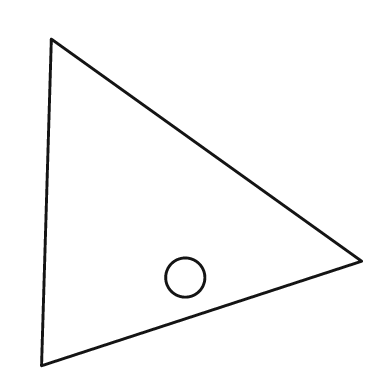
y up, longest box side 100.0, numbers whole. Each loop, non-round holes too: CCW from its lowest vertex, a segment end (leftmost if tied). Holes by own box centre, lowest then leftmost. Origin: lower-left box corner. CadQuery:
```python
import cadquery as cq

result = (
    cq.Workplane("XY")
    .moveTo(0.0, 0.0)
    .lineTo(98.0, 32.0)
    .lineTo(3.0, 100.0)
    .close()
    .moveTo(44.0, 27.0)
    .circle(6.0)
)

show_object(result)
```